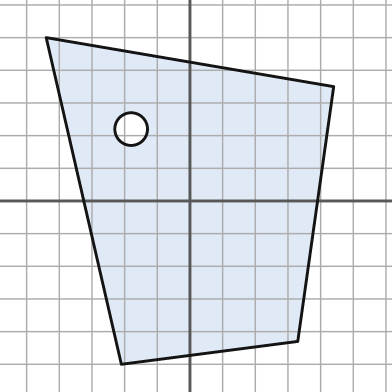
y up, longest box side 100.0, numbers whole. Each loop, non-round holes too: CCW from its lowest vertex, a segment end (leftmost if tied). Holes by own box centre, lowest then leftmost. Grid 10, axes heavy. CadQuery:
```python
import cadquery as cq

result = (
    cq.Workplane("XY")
    .moveTo(-21.0, -50.0)
    .lineTo(33.0, -43.0)
    .lineTo(44.0, 35.0)
    .lineTo(-44.0, 50.0)
    .close()
    .moveTo(-18.0, 22.0)
    .circle(5.0)
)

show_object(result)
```